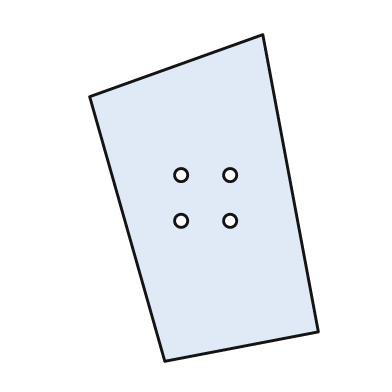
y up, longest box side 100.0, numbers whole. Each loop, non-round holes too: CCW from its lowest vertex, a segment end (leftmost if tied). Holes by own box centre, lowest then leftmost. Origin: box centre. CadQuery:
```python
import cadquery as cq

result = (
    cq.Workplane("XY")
    .moveTo(-12.0, -50.0)
    .lineTo(35.0, -41.0)
    .lineTo(18.0, 50.0)
    .lineTo(-35.0, 31.0)
    .close()
    .moveTo(-7.0, -7.0)
    .circle(2.0)
    .moveTo(8.0, -7.0)
    .circle(2.0)
    .moveTo(-7.0, 7.0)
    .circle(2.0)
    .moveTo(8.0, 7.0)
    .circle(2.0)
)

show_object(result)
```